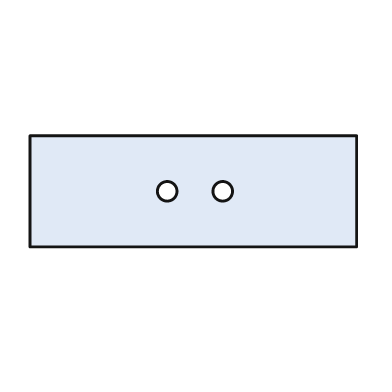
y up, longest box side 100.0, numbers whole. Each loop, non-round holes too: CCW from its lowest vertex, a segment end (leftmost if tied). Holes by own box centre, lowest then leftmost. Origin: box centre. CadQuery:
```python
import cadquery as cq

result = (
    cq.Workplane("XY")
    .moveTo(-50.0, -17.0)
    .lineTo(50.0, -17.0)
    .lineTo(50.0, 17.0)
    .lineTo(-50.0, 17.0)
    .close()
    .moveTo(-8.0, 0.0)
    .circle(3.0)
    .moveTo(9.0, 0.0)
    .circle(3.0)
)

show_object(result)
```